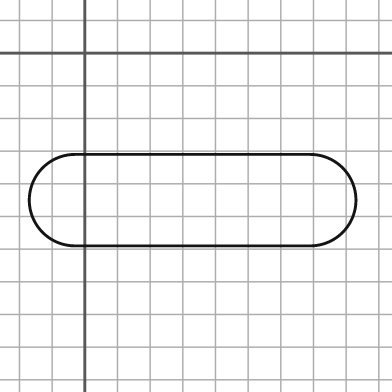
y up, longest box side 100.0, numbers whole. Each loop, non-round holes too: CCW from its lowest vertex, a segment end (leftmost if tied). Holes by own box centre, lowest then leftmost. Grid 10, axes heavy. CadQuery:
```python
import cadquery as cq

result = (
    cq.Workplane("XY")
    .moveTo(-3.0, -59.0)
    .lineTo(69.0, -59.0)
    .threePointArc((83.0, -45.0), (69.0, -31.0))
    .lineTo(-3.0, -31.0)
    .threePointArc((-17.0, -45.0), (-3.0, -59.0))
    .close()
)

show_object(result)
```